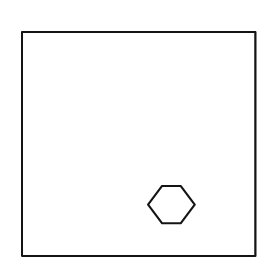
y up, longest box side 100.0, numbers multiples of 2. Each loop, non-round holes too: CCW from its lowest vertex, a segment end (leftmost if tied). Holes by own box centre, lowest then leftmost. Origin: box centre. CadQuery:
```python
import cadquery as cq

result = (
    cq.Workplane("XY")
    .moveTo(-50.0, -48.0)
    .lineTo(50.0, -48.0)
    .lineTo(50.0, 48.0)
    .lineTo(-50.0, 48.0)
    .close()
    .moveTo(10.0, -34.0)
    .lineTo(18.0, -34.0)
    .lineTo(24.0, -26.0)
    .lineTo(18.0, -18.0)
    .lineTo(10.0, -18.0)
    .lineTo(4.0, -26.0)
    .close()
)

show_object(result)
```